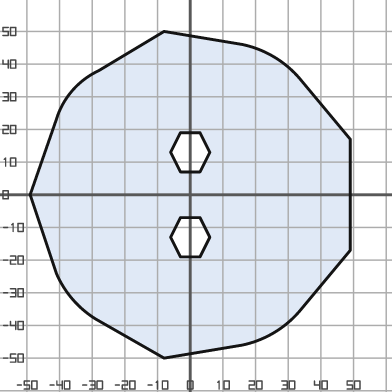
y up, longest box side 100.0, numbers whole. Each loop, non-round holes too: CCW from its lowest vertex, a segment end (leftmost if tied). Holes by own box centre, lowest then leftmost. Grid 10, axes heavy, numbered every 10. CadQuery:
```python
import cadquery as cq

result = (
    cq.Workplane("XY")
    .moveTo(-8.0, -50.0)
    .lineTo(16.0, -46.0)
    .threePointArc((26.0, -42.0), (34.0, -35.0))
    .lineTo(49.0, -17.0)
    .lineTo(49.0, 17.0)
    .lineTo(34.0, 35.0)
    .threePointArc((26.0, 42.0), (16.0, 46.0))
    .lineTo(-8.0, 50.0)
    .lineTo(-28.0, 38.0)
    .threePointArc((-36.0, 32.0), (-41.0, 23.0))
    .lineTo(-49.0, 0.0)
    .lineTo(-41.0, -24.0)
    .threePointArc((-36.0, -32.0), (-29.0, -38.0))
    .close()
    .moveTo(-3.0, -19.0)
    .lineTo(3.0, -19.0)
    .lineTo(6.0, -13.0)
    .lineTo(3.0, -7.0)
    .lineTo(-3.0, -7.0)
    .lineTo(-6.0, -13.0)
    .close()
    .moveTo(-3.0, 7.0)
    .lineTo(3.0, 7.0)
    .lineTo(6.0, 13.0)
    .lineTo(3.0, 19.0)
    .lineTo(-3.0, 19.0)
    .lineTo(-6.0, 13.0)
    .close()
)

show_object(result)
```